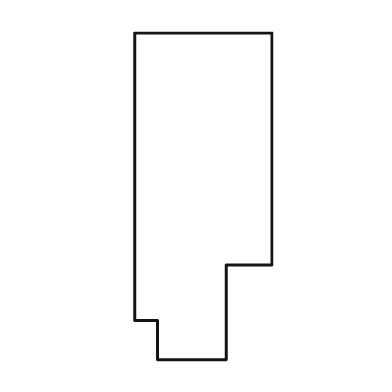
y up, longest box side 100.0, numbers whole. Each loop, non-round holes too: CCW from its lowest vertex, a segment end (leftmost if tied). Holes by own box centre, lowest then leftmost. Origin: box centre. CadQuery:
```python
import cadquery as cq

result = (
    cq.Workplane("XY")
    .moveTo(-14.0, -50.0)
    .lineTo(7.0, -50.0)
    .lineTo(7.0, -21.0)
    .lineTo(21.0, -21.0)
    .lineTo(21.0, 50.0)
    .lineTo(-21.0, 50.0)
    .lineTo(-21.0, -38.0)
    .lineTo(-14.0, -38.0)
    .close()
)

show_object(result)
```